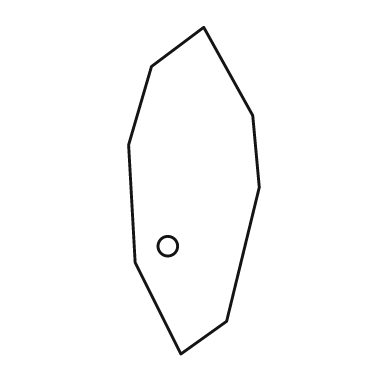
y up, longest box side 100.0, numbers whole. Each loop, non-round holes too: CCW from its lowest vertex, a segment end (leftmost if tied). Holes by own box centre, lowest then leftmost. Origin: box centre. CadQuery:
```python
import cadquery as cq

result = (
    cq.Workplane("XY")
    .moveTo(-4.0, -50.0)
    .lineTo(10.0, -40.0)
    .lineTo(20.0, 1.0)
    .lineTo(18.0, 23.0)
    .lineTo(3.0, 50.0)
    .lineTo(-13.0, 38.0)
    .lineTo(-20.0, 14.0)
    .lineTo(-18.0, -22.0)
    .close()
    .moveTo(-8.0, -17.0)
    .circle(3.0)
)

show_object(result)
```